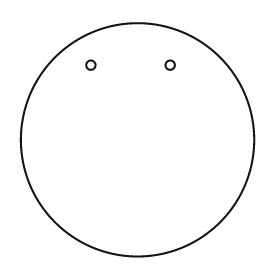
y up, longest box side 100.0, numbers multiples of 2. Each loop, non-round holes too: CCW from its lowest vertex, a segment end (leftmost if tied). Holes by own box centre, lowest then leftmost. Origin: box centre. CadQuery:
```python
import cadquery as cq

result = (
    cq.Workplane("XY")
    .moveTo(0.0, 0.0)
    .circle(50.0)
    .moveTo(-20.0, 32.0)
    .circle(2.0)
    .moveTo(14.0, 32.0)
    .circle(2.0)
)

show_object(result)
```